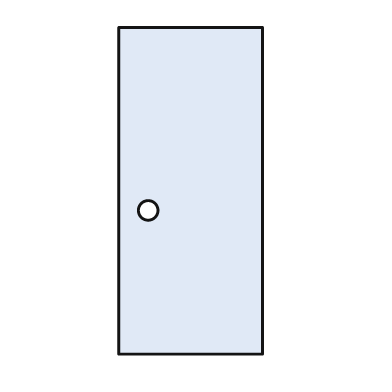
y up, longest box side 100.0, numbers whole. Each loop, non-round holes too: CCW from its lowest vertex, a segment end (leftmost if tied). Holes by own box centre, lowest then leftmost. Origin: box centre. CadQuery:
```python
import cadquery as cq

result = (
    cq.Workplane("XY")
    .moveTo(-22.0, -50.0)
    .lineTo(22.0, -50.0)
    .lineTo(22.0, 50.0)
    .lineTo(-22.0, 50.0)
    .close()
    .moveTo(-13.0, -6.0)
    .circle(3.0)
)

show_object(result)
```